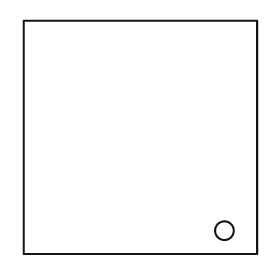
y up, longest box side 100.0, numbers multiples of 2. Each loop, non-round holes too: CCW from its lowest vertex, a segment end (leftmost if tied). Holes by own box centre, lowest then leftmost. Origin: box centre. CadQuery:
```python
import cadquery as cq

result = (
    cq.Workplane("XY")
    .moveTo(-50.0, -50.0)
    .lineTo(50.0, -50.0)
    .lineTo(50.0, 50.0)
    .lineTo(-50.0, 50.0)
    .close()
    .moveTo(36.0, -40.0)
    .circle(4.0)
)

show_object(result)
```